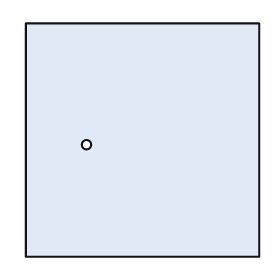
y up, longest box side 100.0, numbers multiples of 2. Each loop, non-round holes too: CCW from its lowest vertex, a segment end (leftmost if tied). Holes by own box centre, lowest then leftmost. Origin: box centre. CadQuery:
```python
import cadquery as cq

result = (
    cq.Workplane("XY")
    .moveTo(-50.0, -50.0)
    .lineTo(50.0, -50.0)
    .lineTo(50.0, 50.0)
    .lineTo(-50.0, 50.0)
    .close()
    .moveTo(-24.0, -2.0)
    .circle(2.0)
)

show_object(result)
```